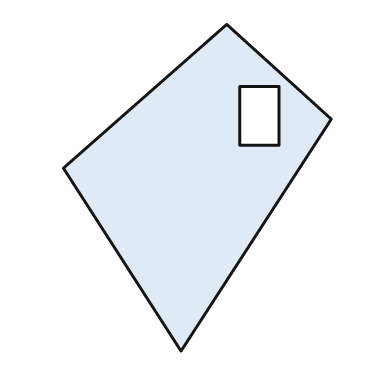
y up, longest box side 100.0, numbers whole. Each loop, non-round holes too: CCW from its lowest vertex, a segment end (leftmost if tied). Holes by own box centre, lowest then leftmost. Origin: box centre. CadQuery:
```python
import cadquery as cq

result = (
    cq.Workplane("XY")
    .moveTo(-5.0, -50.0)
    .lineTo(41.0, 21.0)
    .lineTo(9.0, 50.0)
    .lineTo(-41.0, 6.0)
    .close()
    .moveTo(13.0, 13.0)
    .lineTo(25.0, 13.0)
    .lineTo(25.0, 31.0)
    .lineTo(13.0, 31.0)
    .close()
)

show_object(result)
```